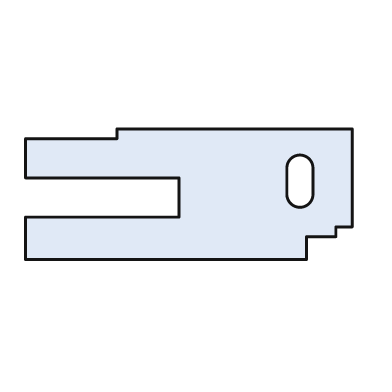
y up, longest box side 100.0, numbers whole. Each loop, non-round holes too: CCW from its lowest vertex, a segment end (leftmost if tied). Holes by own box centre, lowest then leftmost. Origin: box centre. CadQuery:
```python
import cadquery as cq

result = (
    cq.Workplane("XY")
    .moveTo(-50.0, -20.0)
    .lineTo(36.0, -20.0)
    .lineTo(36.0, -13.0)
    .lineTo(45.0, -13.0)
    .lineTo(45.0, -10.0)
    .lineTo(50.0, -10.0)
    .lineTo(50.0, 20.0)
    .lineTo(-22.0, 20.0)
    .lineTo(-22.0, 17.0)
    .lineTo(-50.0, 17.0)
    .lineTo(-50.0, 5.0)
    .lineTo(-3.0, 5.0)
    .lineTo(-3.0, -7.0)
    .lineTo(-50.0, -7.0)
    .close()
    .moveTo(30.0, 0.0)
    .threePointArc((34.0, -4.0), (38.0, 0.0))
    .lineTo(38.0, 8.0)
    .threePointArc((34.0, 12.0), (30.0, 8.0))
    .close()
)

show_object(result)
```